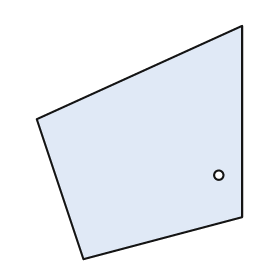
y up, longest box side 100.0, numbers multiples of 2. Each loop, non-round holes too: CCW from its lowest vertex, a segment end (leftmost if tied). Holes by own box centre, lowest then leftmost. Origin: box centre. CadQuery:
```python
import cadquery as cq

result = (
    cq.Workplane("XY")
    .moveTo(-24.0, -50.0)
    .lineTo(44.0, -32.0)
    .lineTo(44.0, 50.0)
    .lineTo(-44.0, 10.0)
    .close()
    .moveTo(34.0, -14.0)
    .circle(2.0)
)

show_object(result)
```